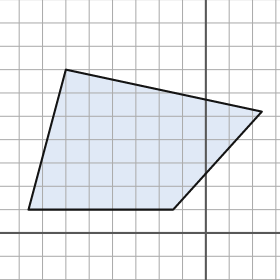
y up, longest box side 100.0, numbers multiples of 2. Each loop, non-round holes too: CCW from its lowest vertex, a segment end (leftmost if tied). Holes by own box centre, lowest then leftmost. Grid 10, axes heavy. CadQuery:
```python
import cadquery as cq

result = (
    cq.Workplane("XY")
    .moveTo(-76.0, 10.0)
    .lineTo(-14.0, 10.0)
    .lineTo(24.0, 52.0)
    .lineTo(-60.0, 70.0)
    .close()
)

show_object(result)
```